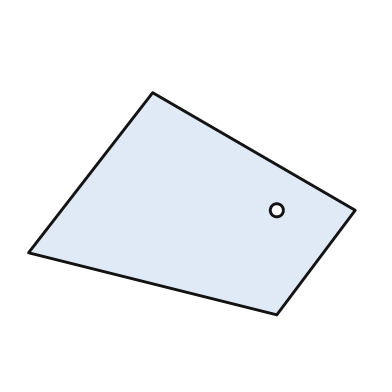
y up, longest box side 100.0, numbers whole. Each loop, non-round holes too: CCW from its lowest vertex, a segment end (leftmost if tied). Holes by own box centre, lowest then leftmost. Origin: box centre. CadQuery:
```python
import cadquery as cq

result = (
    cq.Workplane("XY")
    .moveTo(26.0, -34.0)
    .lineTo(50.0, -2.0)
    .lineTo(-12.0, 34.0)
    .lineTo(-50.0, -15.0)
    .close()
    .moveTo(26.0, -2.0)
    .circle(2.0)
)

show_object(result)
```